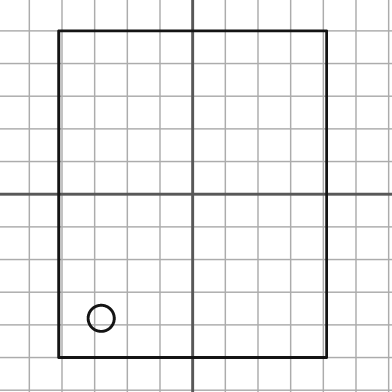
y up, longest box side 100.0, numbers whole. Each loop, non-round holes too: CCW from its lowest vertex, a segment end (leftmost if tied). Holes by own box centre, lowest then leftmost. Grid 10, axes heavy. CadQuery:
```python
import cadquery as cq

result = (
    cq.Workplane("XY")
    .moveTo(-41.0, -50.0)
    .lineTo(41.0, -50.0)
    .lineTo(41.0, 50.0)
    .lineTo(-41.0, 50.0)
    .close()
    .moveTo(-28.0, -38.0)
    .circle(4.0)
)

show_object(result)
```